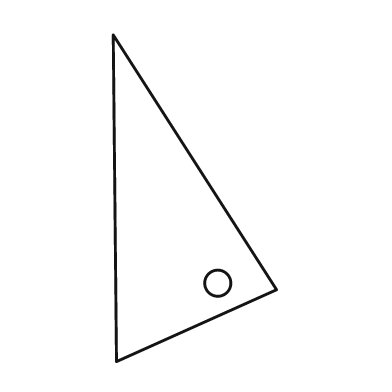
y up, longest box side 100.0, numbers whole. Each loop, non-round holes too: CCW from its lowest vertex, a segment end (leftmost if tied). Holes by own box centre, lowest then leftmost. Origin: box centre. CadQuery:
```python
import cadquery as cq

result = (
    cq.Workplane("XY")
    .moveTo(-24.0, -50.0)
    .lineTo(25.0, -28.0)
    .lineTo(-25.0, 50.0)
    .close()
    .moveTo(7.0, -26.0)
    .circle(4.0)
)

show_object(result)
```